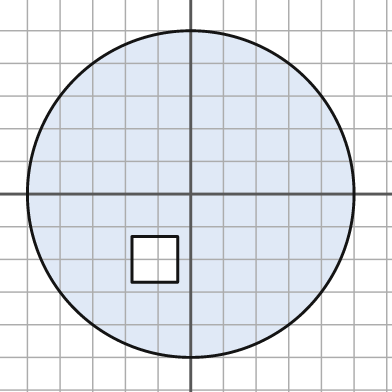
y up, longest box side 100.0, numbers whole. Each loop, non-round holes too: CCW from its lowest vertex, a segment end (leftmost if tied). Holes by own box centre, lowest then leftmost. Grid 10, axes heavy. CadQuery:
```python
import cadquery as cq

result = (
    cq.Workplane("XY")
    .moveTo(0.0, 0.0)
    .circle(50.0)
    .moveTo(-18.0, -27.0)
    .lineTo(-4.0, -27.0)
    .lineTo(-4.0, -13.0)
    .lineTo(-18.0, -13.0)
    .close()
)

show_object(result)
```